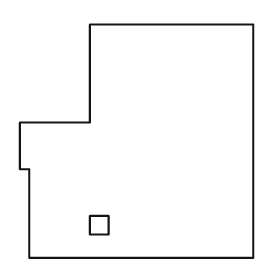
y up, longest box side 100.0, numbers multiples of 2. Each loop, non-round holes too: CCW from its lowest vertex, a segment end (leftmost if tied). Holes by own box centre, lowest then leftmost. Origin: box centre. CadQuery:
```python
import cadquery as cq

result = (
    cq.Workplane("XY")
    .moveTo(-46.0, -50.0)
    .lineTo(50.0, -50.0)
    .lineTo(50.0, 50.0)
    .lineTo(-20.0, 50.0)
    .lineTo(-20.0, 8.0)
    .lineTo(-50.0, 8.0)
    .lineTo(-50.0, -12.0)
    .lineTo(-46.0, -12.0)
    .close()
    .moveTo(-20.0, -40.0)
    .lineTo(-12.0, -40.0)
    .lineTo(-12.0, -32.0)
    .lineTo(-20.0, -32.0)
    .close()
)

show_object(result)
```